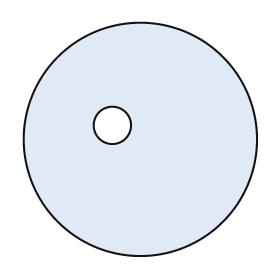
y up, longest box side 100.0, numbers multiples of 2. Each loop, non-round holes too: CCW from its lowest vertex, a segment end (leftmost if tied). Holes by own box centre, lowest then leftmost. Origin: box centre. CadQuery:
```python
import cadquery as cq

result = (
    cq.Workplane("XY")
    .moveTo(0.0, 0.0)
    .circle(50.0)
    .moveTo(-12.0, 6.0)
    .circle(8.0)
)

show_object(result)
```